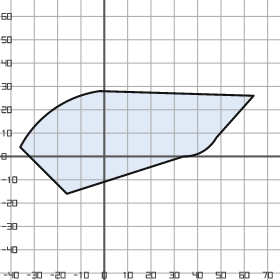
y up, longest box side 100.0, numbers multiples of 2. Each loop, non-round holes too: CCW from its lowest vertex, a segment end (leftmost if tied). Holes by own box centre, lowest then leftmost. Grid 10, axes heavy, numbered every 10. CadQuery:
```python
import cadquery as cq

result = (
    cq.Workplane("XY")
    .moveTo(-16.0, -16.0)
    .lineTo(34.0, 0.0)
    .threePointArc((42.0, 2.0), (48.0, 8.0))
    .lineTo(64.0, 26.0)
    .lineTo(-2.0, 28.0)
    .threePointArc((-22.0, 20.0), (-36.0, 4.0))
    .close()
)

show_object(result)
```